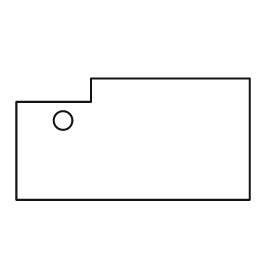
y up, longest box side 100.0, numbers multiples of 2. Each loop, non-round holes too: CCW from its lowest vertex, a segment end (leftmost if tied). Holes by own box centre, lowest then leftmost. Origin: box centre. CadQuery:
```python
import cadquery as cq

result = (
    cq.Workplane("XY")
    .moveTo(-50.0, -26.0)
    .lineTo(50.0, -26.0)
    .lineTo(50.0, 26.0)
    .lineTo(-18.0, 26.0)
    .lineTo(-18.0, 16.0)
    .lineTo(-50.0, 16.0)
    .close()
    .moveTo(-30.0, 8.0)
    .circle(4.0)
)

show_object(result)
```